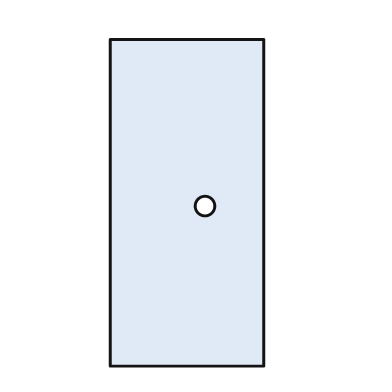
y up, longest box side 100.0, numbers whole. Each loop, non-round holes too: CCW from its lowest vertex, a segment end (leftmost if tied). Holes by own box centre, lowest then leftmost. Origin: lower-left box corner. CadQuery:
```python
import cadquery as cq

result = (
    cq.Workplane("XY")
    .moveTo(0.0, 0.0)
    .lineTo(47.0, 0.0)
    .lineTo(47.0, 100.0)
    .lineTo(0.0, 100.0)
    .close()
    .moveTo(29.0, 49.0)
    .circle(3.0)
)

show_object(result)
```